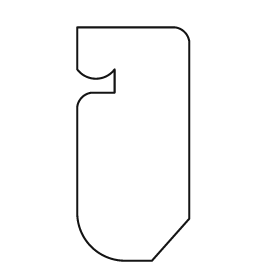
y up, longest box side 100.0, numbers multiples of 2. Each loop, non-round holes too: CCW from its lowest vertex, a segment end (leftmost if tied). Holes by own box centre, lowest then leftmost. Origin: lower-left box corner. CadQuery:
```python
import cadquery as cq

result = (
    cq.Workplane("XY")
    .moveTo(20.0, 0.0)
    .lineTo(32.0, 0.0)
    .lineTo(48.0, 18.0)
    .lineTo(48.0, 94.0)
    .threePointArc((46.0, 98.0), (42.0, 100.0))
    .lineTo(0.0, 100.0)
    .lineTo(0.0, 82.0)
    .threePointArc((8.0, 78.0), (16.0, 82.0))
    .lineTo(16.0, 72.0)
    .lineTo(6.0, 72.0)
    .threePointArc((2.0, 70.0), (0.0, 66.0))
    .lineTo(0.0, 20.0)
    .threePointArc((6.0, 6.0), (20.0, 0.0))
    .close()
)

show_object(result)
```